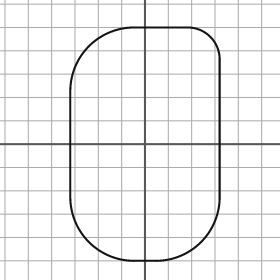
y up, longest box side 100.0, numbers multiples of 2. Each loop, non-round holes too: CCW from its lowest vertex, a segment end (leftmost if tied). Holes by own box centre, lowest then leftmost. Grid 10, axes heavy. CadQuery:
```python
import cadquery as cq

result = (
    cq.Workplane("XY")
    .moveTo(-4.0, -50.0)
    .lineTo(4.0, -50.0)
    .threePointArc((24.0, -42.0), (32.0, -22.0))
    .lineTo(32.0, 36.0)
    .threePointArc((28.0, 46.0), (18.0, 50.0))
    .lineTo(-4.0, 50.0)
    .threePointArc((-24.0, 42.0), (-32.0, 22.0))
    .lineTo(-32.0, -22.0)
    .threePointArc((-24.0, -42.0), (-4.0, -50.0))
    .close()
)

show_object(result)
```